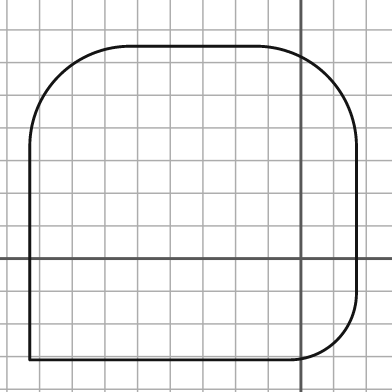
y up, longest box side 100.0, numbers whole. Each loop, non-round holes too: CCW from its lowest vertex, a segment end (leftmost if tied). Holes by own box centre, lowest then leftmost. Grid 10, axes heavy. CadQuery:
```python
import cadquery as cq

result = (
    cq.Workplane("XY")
    .moveTo(-83.0, -31.0)
    .lineTo(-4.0, -31.0)
    .threePointArc((11.0, -25.0), (17.0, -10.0))
    .lineTo(17.0, 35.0)
    .threePointArc((8.0, 56.0), (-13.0, 65.0))
    .lineTo(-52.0, 65.0)
    .threePointArc((-74.0, 56.0), (-83.0, 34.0))
    .close()
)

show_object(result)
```